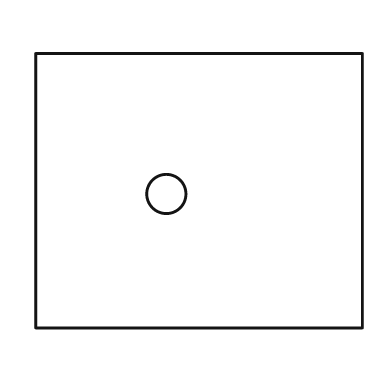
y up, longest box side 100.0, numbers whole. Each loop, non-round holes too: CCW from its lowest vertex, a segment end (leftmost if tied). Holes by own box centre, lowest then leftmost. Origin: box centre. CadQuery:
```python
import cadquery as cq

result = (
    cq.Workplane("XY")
    .moveTo(-50.0, -42.0)
    .lineTo(50.0, -42.0)
    .lineTo(50.0, 42.0)
    .lineTo(-50.0, 42.0)
    .close()
    .moveTo(-10.0, -1.0)
    .circle(6.0)
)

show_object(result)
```